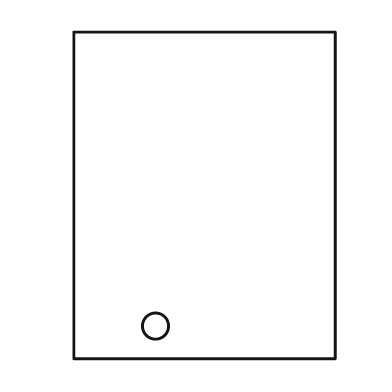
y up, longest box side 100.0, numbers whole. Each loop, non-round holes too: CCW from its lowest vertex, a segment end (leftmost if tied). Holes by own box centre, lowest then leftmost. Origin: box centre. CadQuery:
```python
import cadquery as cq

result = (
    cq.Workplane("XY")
    .moveTo(-40.0, -50.0)
    .lineTo(40.0, -50.0)
    .lineTo(40.0, 50.0)
    .lineTo(-40.0, 50.0)
    .close()
    .moveTo(-15.0, -40.0)
    .circle(4.0)
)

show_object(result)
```